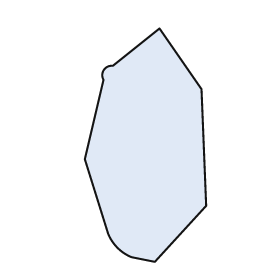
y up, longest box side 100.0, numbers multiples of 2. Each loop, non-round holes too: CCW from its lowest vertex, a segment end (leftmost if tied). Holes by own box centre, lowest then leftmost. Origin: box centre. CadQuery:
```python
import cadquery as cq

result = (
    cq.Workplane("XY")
    .moveTo(4.0, -50.0)
    .lineTo(26.0, -26.0)
    .lineTo(24.0, 24.0)
    .lineTo(6.0, 50.0)
    .lineTo(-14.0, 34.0)
    .threePointArc((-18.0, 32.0), (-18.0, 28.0))
    .lineTo(-26.0, -6.0)
    .lineTo(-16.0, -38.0)
    .threePointArc((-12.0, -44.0), (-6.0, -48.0))
    .close()
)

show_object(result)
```